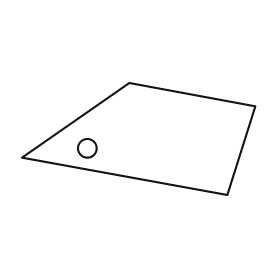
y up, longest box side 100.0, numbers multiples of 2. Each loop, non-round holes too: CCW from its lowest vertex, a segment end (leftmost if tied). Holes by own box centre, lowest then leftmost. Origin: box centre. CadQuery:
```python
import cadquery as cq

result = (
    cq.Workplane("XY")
    .moveTo(38.0, -24.0)
    .lineTo(50.0, 14.0)
    .lineTo(-4.0, 24.0)
    .lineTo(-50.0, -8.0)
    .close()
    .moveTo(-22.0, -4.0)
    .circle(4.0)
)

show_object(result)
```